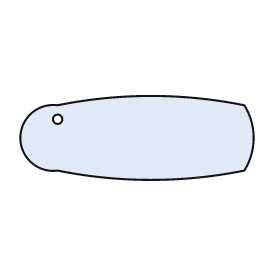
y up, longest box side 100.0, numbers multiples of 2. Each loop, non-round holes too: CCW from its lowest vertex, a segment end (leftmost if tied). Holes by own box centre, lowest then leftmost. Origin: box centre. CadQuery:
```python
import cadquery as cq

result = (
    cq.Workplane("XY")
    .moveTo(-34.0, -14.0)
    .threePointArc((6.0, -18.0), (46.0, -14.0))
    .threePointArc((50.0, 0.0), (46.0, 14.0))
    .threePointArc((6.0, 18.0), (-34.0, 14.0))
    .threePointArc((-50.0, 0.0), (-34.0, -14.0))
    .close()
    .moveTo(-34.0, 8.0)
    .circle(2.0)
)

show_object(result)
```